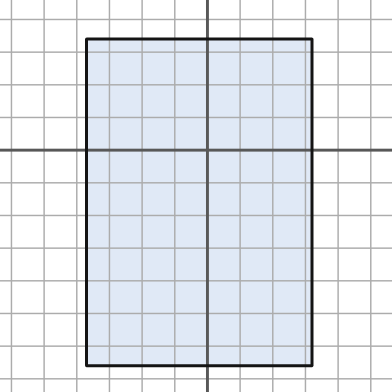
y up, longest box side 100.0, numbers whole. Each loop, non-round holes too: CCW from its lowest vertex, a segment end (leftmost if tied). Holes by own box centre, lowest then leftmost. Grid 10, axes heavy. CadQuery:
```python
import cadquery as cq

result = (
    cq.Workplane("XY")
    .moveTo(-37.0, -66.0)
    .lineTo(32.0, -66.0)
    .lineTo(32.0, 34.0)
    .lineTo(-37.0, 34.0)
    .close()
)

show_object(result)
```